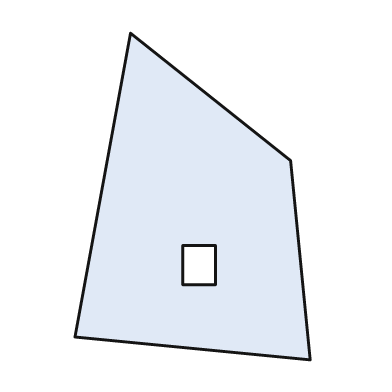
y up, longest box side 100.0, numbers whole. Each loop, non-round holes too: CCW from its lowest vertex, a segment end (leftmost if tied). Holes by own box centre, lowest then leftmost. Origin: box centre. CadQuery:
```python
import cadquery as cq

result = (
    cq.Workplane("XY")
    .moveTo(36.0, -50.0)
    .lineTo(30.0, 11.0)
    .lineTo(-19.0, 50.0)
    .lineTo(-36.0, -43.0)
    .close()
    .moveTo(-3.0, -27.0)
    .lineTo(7.0, -27.0)
    .lineTo(7.0, -15.0)
    .lineTo(-3.0, -15.0)
    .close()
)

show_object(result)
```